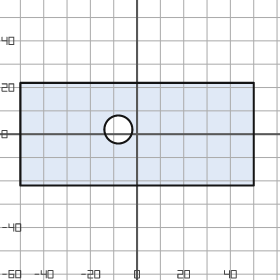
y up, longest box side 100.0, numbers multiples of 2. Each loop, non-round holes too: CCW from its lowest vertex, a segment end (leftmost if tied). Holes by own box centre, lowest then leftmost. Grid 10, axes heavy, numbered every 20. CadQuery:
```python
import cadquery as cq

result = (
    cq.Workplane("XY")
    .moveTo(-50.0, -22.0)
    .lineTo(50.0, -22.0)
    .lineTo(50.0, 22.0)
    .lineTo(-50.0, 22.0)
    .close()
    .moveTo(-8.0, 2.0)
    .circle(6.0)
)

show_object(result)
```